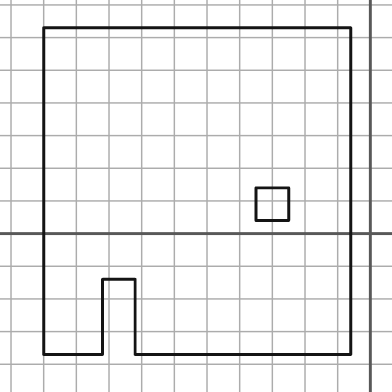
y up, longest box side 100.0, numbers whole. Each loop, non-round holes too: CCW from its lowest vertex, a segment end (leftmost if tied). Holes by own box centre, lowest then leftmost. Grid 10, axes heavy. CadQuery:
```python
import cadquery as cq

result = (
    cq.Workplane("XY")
    .moveTo(-100.0, -37.0)
    .lineTo(-82.0, -37.0)
    .lineTo(-82.0, -14.0)
    .lineTo(-72.0, -14.0)
    .lineTo(-72.0, -37.0)
    .lineTo(-6.0, -37.0)
    .lineTo(-6.0, 63.0)
    .lineTo(-100.0, 63.0)
    .close()
    .moveTo(-35.0, 4.0)
    .lineTo(-25.0, 4.0)
    .lineTo(-25.0, 14.0)
    .lineTo(-35.0, 14.0)
    .close()
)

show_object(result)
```